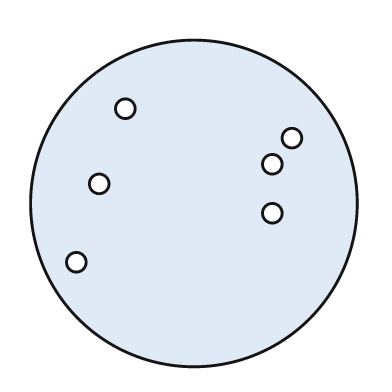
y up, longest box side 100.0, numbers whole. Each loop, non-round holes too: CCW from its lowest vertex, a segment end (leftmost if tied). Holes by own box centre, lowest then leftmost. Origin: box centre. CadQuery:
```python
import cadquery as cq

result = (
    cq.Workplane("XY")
    .moveTo(0.0, 0.0)
    .circle(50.0)
    .moveTo(-36.0, -18.0)
    .circle(3.0)
    .moveTo(24.0, -3.0)
    .circle(3.0)
    .moveTo(-29.0, 6.0)
    .circle(3.0)
    .moveTo(24.0, 12.0)
    .circle(3.0)
    .moveTo(30.0, 20.0)
    .circle(3.0)
    .moveTo(-21.0, 29.0)
    .circle(3.0)
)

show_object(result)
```